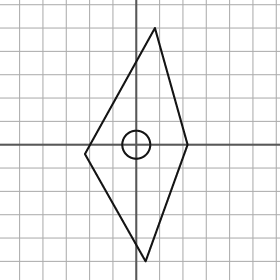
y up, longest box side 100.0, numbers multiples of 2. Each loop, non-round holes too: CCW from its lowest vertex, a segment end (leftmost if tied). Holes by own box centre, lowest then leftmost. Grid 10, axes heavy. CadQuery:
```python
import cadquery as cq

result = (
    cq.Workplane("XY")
    .moveTo(4.0, -50.0)
    .lineTo(22.0, 0.0)
    .lineTo(8.0, 50.0)
    .lineTo(-22.0, -4.0)
    .close()
    .moveTo(0.0, 0.0)
    .circle(6.0)
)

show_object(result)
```